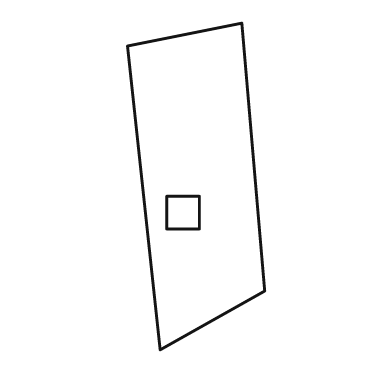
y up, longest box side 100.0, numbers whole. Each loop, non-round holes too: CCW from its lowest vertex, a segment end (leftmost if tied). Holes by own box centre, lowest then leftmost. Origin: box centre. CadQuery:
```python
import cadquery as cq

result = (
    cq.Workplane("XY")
    .moveTo(-11.0, -50.0)
    .lineTo(21.0, -32.0)
    .lineTo(14.0, 50.0)
    .lineTo(-21.0, 43.0)
    .close()
    .moveTo(-9.0, -13.0)
    .lineTo(1.0, -13.0)
    .lineTo(1.0, -3.0)
    .lineTo(-9.0, -3.0)
    .close()
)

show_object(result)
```